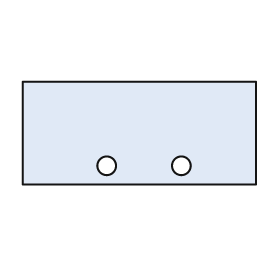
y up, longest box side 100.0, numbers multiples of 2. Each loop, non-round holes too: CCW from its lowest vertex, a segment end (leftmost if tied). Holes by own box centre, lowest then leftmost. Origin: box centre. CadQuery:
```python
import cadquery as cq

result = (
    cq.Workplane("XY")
    .moveTo(-50.0, -22.0)
    .lineTo(50.0, -22.0)
    .lineTo(50.0, 22.0)
    .lineTo(-50.0, 22.0)
    .close()
    .moveTo(-14.0, -14.0)
    .circle(4.0)
    .moveTo(18.0, -14.0)
    .circle(4.0)
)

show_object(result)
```